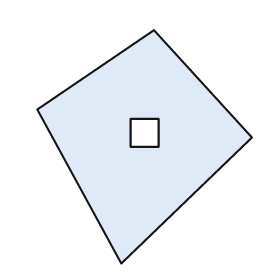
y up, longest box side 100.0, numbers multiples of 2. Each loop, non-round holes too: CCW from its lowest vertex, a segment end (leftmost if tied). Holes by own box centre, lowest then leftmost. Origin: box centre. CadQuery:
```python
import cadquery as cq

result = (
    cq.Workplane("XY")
    .moveTo(-10.0, -50.0)
    .lineTo(46.0, 4.0)
    .lineTo(4.0, 50.0)
    .lineTo(-46.0, 16.0)
    .close()
    .moveTo(-6.0, 0.0)
    .lineTo(6.0, 0.0)
    .lineTo(6.0, 12.0)
    .lineTo(-6.0, 12.0)
    .close()
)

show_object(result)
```